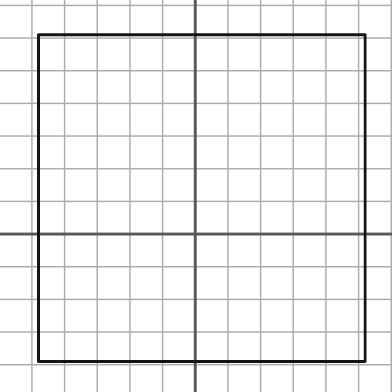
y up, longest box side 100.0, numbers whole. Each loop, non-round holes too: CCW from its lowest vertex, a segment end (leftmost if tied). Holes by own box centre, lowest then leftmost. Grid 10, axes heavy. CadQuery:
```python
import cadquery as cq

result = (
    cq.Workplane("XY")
    .moveTo(-48.0, -39.0)
    .lineTo(52.0, -39.0)
    .lineTo(52.0, 61.0)
    .lineTo(-48.0, 61.0)
    .close()
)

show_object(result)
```